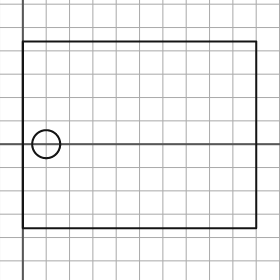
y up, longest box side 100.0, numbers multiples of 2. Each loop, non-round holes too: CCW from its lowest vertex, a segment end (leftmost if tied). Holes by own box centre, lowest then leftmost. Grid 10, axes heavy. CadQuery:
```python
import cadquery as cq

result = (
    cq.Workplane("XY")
    .moveTo(0.0, -36.0)
    .lineTo(100.0, -36.0)
    .lineTo(100.0, 44.0)
    .lineTo(0.0, 44.0)
    .close()
    .moveTo(10.0, 0.0)
    .circle(6.0)
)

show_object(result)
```